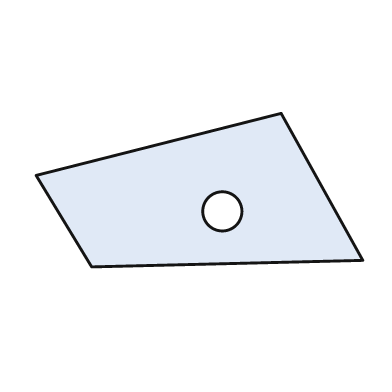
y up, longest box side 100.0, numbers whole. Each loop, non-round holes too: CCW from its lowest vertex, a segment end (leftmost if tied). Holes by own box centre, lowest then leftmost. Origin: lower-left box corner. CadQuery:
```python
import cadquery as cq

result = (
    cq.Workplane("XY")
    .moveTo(17.0, 0.0)
    .lineTo(100.0, 2.0)
    .lineTo(75.0, 47.0)
    .lineTo(0.0, 28.0)
    .close()
    .moveTo(57.0, 17.0)
    .circle(6.0)
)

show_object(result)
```